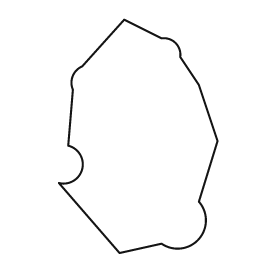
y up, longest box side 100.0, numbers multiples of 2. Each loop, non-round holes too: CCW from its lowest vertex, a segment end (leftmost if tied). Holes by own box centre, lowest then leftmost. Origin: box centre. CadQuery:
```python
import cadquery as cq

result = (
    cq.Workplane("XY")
    .moveTo(-8.0, -50.0)
    .lineTo(10.0, -46.0)
    .threePointArc((26.0, -44.0), (26.0, -28.0))
    .lineTo(34.0, -2.0)
    .lineTo(26.0, 22.0)
    .lineTo(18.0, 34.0)
    .threePointArc((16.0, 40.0), (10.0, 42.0))
    .lineTo(-6.0, 50.0)
    .lineTo(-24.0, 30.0)
    .threePointArc((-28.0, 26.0), (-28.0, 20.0))
    .lineTo(-30.0, -4.0)
    .threePointArc((-24.0, -14.0), (-34.0, -20.0))
    .close()
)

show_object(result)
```